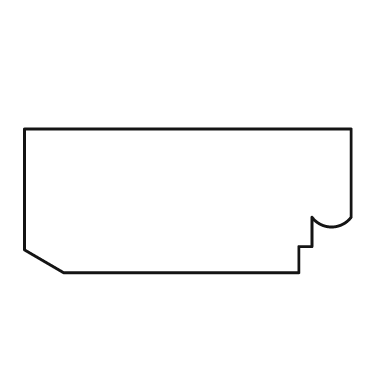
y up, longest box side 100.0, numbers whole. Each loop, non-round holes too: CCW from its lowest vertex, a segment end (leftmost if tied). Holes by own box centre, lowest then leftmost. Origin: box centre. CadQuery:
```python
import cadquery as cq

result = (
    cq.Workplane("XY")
    .moveTo(-38.0, -22.0)
    .lineTo(34.0, -22.0)
    .lineTo(34.0, -14.0)
    .lineTo(38.0, -14.0)
    .lineTo(38.0, -5.0)
    .threePointArc((44.0, -8.0), (50.0, -5.0))
    .lineTo(50.0, 22.0)
    .lineTo(-50.0, 22.0)
    .lineTo(-50.0, -15.0)
    .close()
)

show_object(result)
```